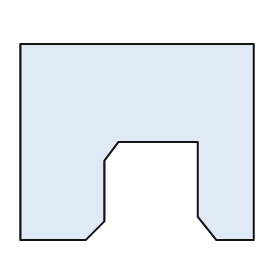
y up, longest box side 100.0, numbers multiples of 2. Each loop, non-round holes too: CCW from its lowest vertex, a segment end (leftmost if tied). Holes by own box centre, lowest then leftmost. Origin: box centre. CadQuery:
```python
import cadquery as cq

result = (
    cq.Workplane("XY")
    .moveTo(-50.0, -42.0)
    .lineTo(-22.0, -42.0)
    .lineTo(-14.0, -34.0)
    .lineTo(-14.0, -8.0)
    .lineTo(-8.0, 0.0)
    .lineTo(26.0, 0.0)
    .lineTo(26.0, -32.0)
    .lineTo(34.0, -42.0)
    .lineTo(50.0, -42.0)
    .lineTo(50.0, 42.0)
    .lineTo(-50.0, 42.0)
    .close()
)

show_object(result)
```